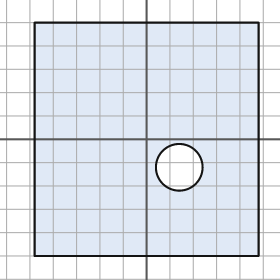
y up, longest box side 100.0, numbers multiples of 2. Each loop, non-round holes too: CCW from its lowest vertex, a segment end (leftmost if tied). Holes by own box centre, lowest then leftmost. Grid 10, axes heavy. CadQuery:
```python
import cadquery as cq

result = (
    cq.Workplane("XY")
    .moveTo(-48.0, -50.0)
    .lineTo(48.0, -50.0)
    .lineTo(48.0, 50.0)
    .lineTo(-48.0, 50.0)
    .close()
    .moveTo(14.0, -12.0)
    .circle(10.0)
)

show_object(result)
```